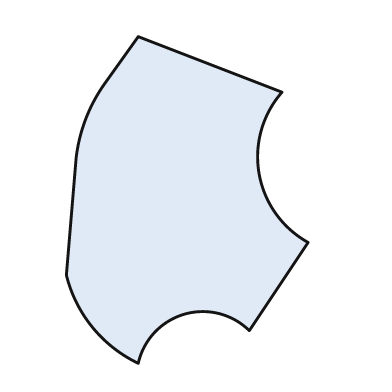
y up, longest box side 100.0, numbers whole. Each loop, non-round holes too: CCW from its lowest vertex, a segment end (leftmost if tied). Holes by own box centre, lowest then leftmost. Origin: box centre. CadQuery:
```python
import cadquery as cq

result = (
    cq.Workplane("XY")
    .moveTo(-15.0, -50.0)
    .threePointArc((-1.0, -35.0), (19.0, -40.0))
    .lineTo(37.0, -13.0)
    .threePointArc((22.0, 8.0), (29.0, 33.0))
    .lineTo(-15.0, 50.0)
    .lineTo(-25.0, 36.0)
    .threePointArc((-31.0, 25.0), (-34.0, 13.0))
    .lineTo(-37.0, -23.0)
    .threePointArc((-29.0, -39.0), (-15.0, -50.0))
    .close()
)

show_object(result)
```